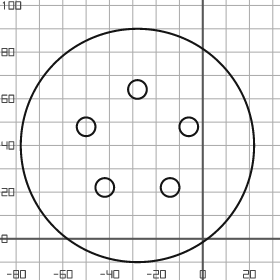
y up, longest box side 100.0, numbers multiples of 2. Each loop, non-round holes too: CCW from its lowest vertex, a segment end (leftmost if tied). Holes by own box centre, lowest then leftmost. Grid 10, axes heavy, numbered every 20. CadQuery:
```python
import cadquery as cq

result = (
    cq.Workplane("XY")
    .moveTo(-28.0, 40.0)
    .circle(50.0)
    .moveTo(-42.0, 22.0)
    .circle(4.0)
    .moveTo(-14.0, 22.0)
    .circle(4.0)
    .moveTo(-50.0, 48.0)
    .circle(4.0)
    .moveTo(-6.0, 48.0)
    .circle(4.0)
    .moveTo(-28.0, 64.0)
    .circle(4.0)
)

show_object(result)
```